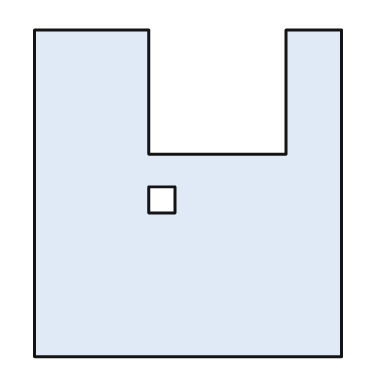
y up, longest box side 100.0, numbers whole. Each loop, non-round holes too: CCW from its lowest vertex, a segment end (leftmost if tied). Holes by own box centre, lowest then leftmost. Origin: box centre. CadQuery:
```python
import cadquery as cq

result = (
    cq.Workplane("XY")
    .moveTo(-47.0, -50.0)
    .lineTo(47.0, -50.0)
    .lineTo(47.0, 50.0)
    .lineTo(30.0, 50.0)
    .lineTo(30.0, 12.0)
    .lineTo(-12.0, 12.0)
    .lineTo(-12.0, 50.0)
    .lineTo(-47.0, 50.0)
    .close()
    .moveTo(-12.0, -6.0)
    .lineTo(-4.0, -6.0)
    .lineTo(-4.0, 2.0)
    .lineTo(-12.0, 2.0)
    .close()
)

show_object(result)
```